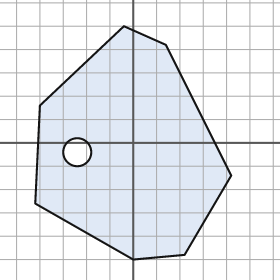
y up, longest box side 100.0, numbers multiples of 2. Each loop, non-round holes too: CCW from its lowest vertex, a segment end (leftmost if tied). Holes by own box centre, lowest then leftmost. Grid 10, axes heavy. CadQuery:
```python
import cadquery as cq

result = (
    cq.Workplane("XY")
    .moveTo(0.0, -50.0)
    .lineTo(22.0, -48.0)
    .lineTo(42.0, -14.0)
    .lineTo(14.0, 42.0)
    .lineTo(-4.0, 50.0)
    .lineTo(-40.0, 16.0)
    .lineTo(-42.0, -26.0)
    .close()
    .moveTo(-24.0, -4.0)
    .circle(6.0)
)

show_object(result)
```